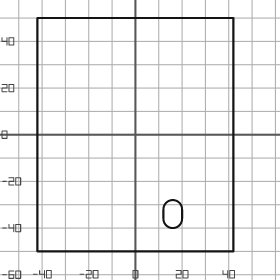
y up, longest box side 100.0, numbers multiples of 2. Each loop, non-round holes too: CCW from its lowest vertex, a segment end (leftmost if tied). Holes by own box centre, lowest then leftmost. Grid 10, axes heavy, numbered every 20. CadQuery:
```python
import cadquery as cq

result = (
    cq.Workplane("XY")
    .moveTo(-42.0, -50.0)
    .lineTo(42.0, -50.0)
    .lineTo(42.0, 50.0)
    .lineTo(-42.0, 50.0)
    .close()
    .moveTo(12.0, -36.0)
    .threePointArc((16.0, -40.0), (20.0, -36.0))
    .lineTo(20.0, -32.0)
    .threePointArc((16.0, -28.0), (12.0, -32.0))
    .close()
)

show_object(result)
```